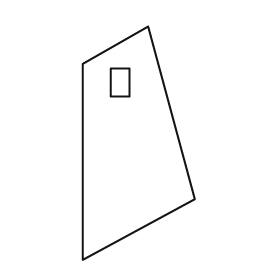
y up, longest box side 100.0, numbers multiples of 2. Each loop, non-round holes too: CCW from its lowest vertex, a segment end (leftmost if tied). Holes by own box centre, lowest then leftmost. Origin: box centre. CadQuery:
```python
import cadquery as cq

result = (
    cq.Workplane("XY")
    .moveTo(-24.0, -50.0)
    .lineTo(24.0, -24.0)
    .lineTo(4.0, 50.0)
    .lineTo(-24.0, 34.0)
    .close()
    .moveTo(-12.0, 20.0)
    .lineTo(-4.0, 20.0)
    .lineTo(-4.0, 32.0)
    .lineTo(-12.0, 32.0)
    .close()
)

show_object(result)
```